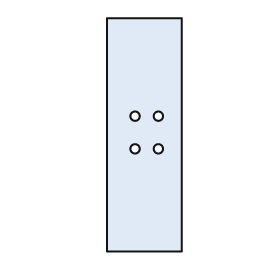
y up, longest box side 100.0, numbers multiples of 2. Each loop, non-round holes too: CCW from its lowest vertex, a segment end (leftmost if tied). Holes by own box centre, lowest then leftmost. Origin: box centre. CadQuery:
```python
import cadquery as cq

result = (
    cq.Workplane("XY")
    .moveTo(-16.0, -50.0)
    .lineTo(16.0, -50.0)
    .lineTo(16.0, 50.0)
    .lineTo(-16.0, 50.0)
    .close()
    .moveTo(-4.0, -6.0)
    .circle(2.0)
    .moveTo(6.0, -6.0)
    .circle(2.0)
    .moveTo(-4.0, 8.0)
    .circle(2.0)
    .moveTo(6.0, 8.0)
    .circle(2.0)
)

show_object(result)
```